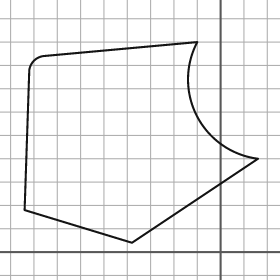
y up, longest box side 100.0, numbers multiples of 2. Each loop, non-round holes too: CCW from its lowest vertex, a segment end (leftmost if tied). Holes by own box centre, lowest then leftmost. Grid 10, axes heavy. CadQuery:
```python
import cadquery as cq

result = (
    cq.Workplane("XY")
    .moveTo(-38.0, 4.0)
    .lineTo(16.0, 40.0)
    .threePointArc((-10.0, 58.0), (-10.0, 90.0))
    .lineTo(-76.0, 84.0)
    .threePointArc((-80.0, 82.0), (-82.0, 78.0))
    .lineTo(-84.0, 18.0)
    .close()
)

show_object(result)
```